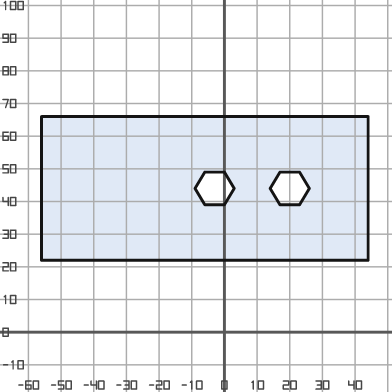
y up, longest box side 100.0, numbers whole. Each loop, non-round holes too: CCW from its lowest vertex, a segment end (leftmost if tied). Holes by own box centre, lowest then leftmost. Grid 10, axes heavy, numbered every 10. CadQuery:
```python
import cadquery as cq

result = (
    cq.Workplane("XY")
    .moveTo(-56.0, 22.0)
    .lineTo(44.0, 22.0)
    .lineTo(44.0, 66.0)
    .lineTo(-56.0, 66.0)
    .close()
    .moveTo(-6.0, 39.0)
    .lineTo(0.0, 39.0)
    .lineTo(3.0, 44.0)
    .lineTo(0.0, 49.0)
    .lineTo(-6.0, 49.0)
    .lineTo(-9.0, 44.0)
    .close()
    .moveTo(17.0, 39.0)
    .lineTo(23.0, 39.0)
    .lineTo(26.0, 44.0)
    .lineTo(23.0, 49.0)
    .lineTo(17.0, 49.0)
    .lineTo(14.0, 44.0)
    .close()
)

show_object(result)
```